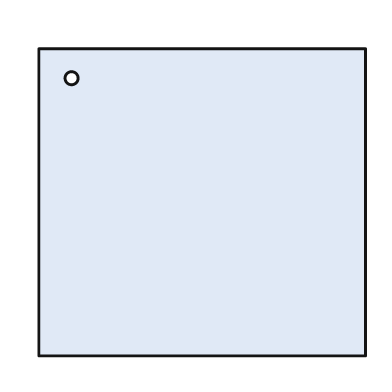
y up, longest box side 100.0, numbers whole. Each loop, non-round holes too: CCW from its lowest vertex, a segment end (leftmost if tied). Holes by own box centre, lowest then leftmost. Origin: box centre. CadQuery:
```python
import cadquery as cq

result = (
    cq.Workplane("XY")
    .moveTo(-50.0, -47.0)
    .lineTo(50.0, -47.0)
    .lineTo(50.0, 47.0)
    .lineTo(-50.0, 47.0)
    .close()
    .moveTo(-40.0, 38.0)
    .circle(2.0)
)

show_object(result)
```